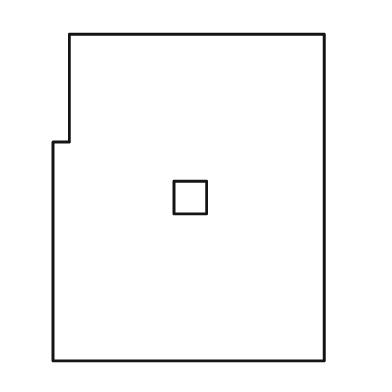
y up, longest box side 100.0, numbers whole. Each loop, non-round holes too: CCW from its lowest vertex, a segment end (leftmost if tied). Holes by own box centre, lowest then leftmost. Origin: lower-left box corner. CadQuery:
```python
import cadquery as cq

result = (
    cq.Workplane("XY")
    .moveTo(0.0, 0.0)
    .lineTo(83.0, 0.0)
    .lineTo(83.0, 100.0)
    .lineTo(5.0, 100.0)
    .lineTo(5.0, 67.0)
    .lineTo(0.0, 67.0)
    .close()
    .moveTo(37.0, 45.0)
    .lineTo(47.0, 45.0)
    .lineTo(47.0, 55.0)
    .lineTo(37.0, 55.0)
    .close()
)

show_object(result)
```